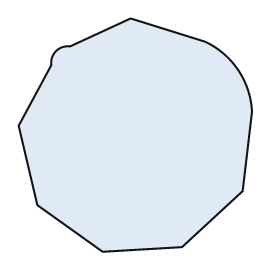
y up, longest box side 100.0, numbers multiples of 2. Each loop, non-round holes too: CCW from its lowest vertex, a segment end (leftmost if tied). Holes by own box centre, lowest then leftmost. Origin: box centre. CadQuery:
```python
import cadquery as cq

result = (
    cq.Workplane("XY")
    .moveTo(-14.0, -50.0)
    .lineTo(20.0, -48.0)
    .lineTo(46.0, -24.0)
    .lineTo(50.0, 10.0)
    .threePointArc((44.0, 28.0), (30.0, 40.0))
    .lineTo(-2.0, 50.0)
    .lineTo(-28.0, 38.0)
    .threePointArc((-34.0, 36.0), (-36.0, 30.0))
    .lineTo(-50.0, 4.0)
    .lineTo(-42.0, -30.0)
    .close()
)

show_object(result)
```